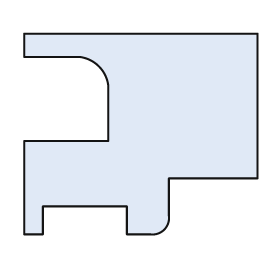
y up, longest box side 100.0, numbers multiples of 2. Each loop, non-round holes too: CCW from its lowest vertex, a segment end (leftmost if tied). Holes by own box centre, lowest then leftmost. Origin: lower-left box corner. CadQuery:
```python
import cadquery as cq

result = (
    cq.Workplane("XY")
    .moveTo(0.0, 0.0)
    .lineTo(8.0, 0.0)
    .lineTo(8.0, 12.0)
    .lineTo(44.0, 12.0)
    .lineTo(44.0, 0.0)
    .lineTo(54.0, 0.0)
    .threePointArc((60.0, 2.0), (62.0, 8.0))
    .lineTo(62.0, 24.0)
    .lineTo(100.0, 24.0)
    .lineTo(100.0, 86.0)
    .lineTo(0.0, 86.0)
    .lineTo(0.0, 76.0)
    .lineTo(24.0, 76.0)
    .threePointArc((32.0, 72.0), (36.0, 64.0))
    .lineTo(36.0, 40.0)
    .lineTo(0.0, 40.0)
    .close()
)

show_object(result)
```